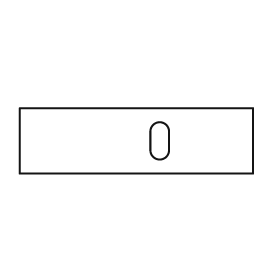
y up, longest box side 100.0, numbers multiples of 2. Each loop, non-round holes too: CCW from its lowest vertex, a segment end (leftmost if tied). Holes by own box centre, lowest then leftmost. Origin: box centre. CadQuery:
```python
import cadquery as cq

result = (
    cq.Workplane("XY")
    .moveTo(-50.0, -14.0)
    .lineTo(50.0, -14.0)
    .lineTo(50.0, 14.0)
    .lineTo(-50.0, 14.0)
    .close()
    .moveTo(6.0, -4.0)
    .threePointArc((10.0, -8.0), (14.0, -4.0))
    .lineTo(14.0, 4.0)
    .threePointArc((10.0, 8.0), (6.0, 4.0))
    .close()
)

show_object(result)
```